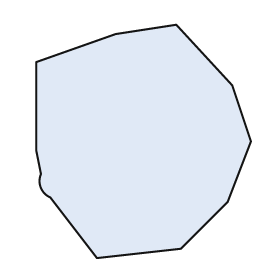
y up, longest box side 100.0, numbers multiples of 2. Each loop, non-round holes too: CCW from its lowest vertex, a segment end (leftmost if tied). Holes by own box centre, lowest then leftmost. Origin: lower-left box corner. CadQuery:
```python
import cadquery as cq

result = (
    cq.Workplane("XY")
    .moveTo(26.0, 0.0)
    .lineTo(62.0, 4.0)
    .lineTo(82.0, 24.0)
    .lineTo(92.0, 50.0)
    .lineTo(84.0, 74.0)
    .lineTo(60.0, 100.0)
    .lineTo(34.0, 96.0)
    .lineTo(0.0, 84.0)
    .lineTo(0.0, 46.0)
    .lineTo(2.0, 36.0)
    .threePointArc((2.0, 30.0), (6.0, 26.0))
    .close()
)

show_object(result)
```